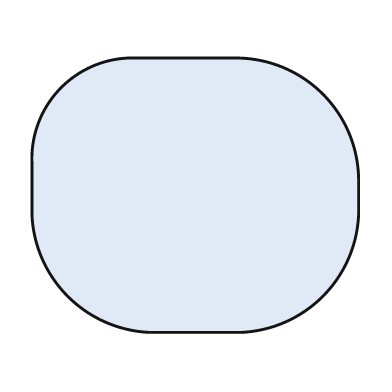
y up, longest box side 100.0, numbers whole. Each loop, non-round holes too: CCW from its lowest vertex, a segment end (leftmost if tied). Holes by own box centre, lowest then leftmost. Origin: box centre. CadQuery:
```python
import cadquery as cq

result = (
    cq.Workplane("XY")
    .moveTo(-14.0, -42.0)
    .lineTo(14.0, -42.0)
    .threePointArc((39.0, -31.0), (50.0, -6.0))
    .lineTo(50.0, 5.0)
    .threePointArc((39.0, 31.0), (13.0, 42.0))
    .lineTo(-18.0, 42.0)
    .threePointArc((-41.0, 33.0), (-50.0, 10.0))
    .lineTo(-50.0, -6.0)
    .threePointArc((-39.0, -31.0), (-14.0, -42.0))
    .close()
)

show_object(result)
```